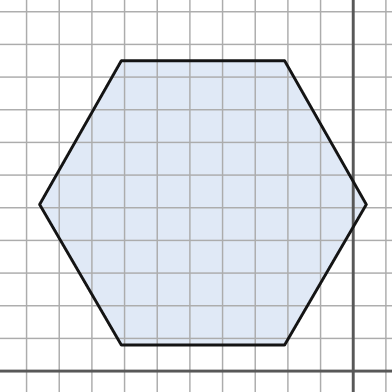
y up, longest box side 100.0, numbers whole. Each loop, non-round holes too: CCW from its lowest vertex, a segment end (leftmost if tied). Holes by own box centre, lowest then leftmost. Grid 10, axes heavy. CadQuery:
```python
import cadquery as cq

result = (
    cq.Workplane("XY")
    .moveTo(-71.0, 8.0)
    .lineTo(-21.0, 8.0)
    .lineTo(4.0, 51.0)
    .lineTo(-21.0, 95.0)
    .lineTo(-71.0, 95.0)
    .lineTo(-96.0, 51.0)
    .close()
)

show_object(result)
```